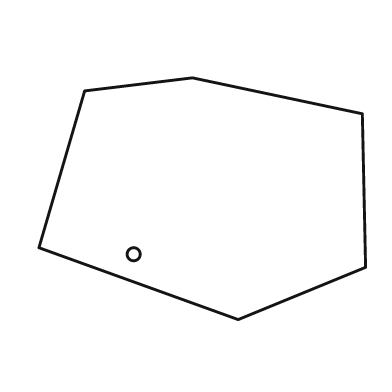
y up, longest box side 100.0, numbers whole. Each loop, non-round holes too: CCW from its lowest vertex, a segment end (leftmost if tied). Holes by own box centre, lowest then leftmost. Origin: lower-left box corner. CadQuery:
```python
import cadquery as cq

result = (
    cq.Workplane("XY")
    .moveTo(61.0, 0.0)
    .lineTo(100.0, 16.0)
    .lineTo(99.0, 63.0)
    .lineTo(47.0, 74.0)
    .lineTo(14.0, 70.0)
    .lineTo(0.0, 22.0)
    .close()
    .moveTo(29.0, 20.0)
    .circle(2.0)
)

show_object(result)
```